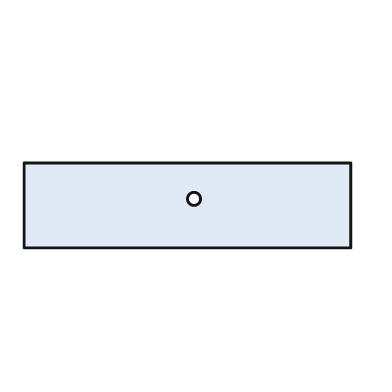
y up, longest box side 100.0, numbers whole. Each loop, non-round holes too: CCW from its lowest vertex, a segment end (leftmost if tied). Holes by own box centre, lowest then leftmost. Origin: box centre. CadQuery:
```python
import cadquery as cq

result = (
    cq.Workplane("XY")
    .moveTo(-50.0, -13.0)
    .lineTo(50.0, -13.0)
    .lineTo(50.0, 13.0)
    .lineTo(-50.0, 13.0)
    .close()
    .moveTo(2.0, 2.0)
    .circle(2.0)
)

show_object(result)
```